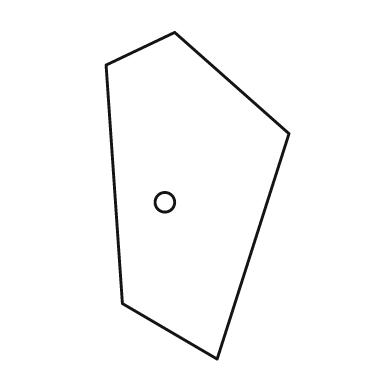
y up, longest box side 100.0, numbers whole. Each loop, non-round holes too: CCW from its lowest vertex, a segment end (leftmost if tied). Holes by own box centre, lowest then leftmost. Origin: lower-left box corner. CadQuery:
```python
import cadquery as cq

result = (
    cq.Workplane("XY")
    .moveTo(34.0, 0.0)
    .lineTo(56.0, 69.0)
    .lineTo(21.0, 100.0)
    .lineTo(0.0, 90.0)
    .lineTo(5.0, 17.0)
    .close()
    .moveTo(18.0, 48.0)
    .circle(3.0)
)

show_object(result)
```